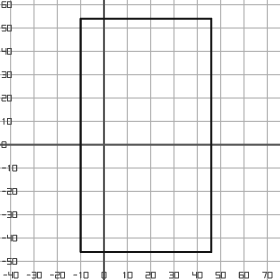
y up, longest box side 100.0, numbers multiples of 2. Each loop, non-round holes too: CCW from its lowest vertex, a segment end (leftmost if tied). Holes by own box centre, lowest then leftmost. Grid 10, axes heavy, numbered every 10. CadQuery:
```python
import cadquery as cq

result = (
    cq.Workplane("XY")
    .moveTo(-10.0, -46.0)
    .lineTo(46.0, -46.0)
    .lineTo(46.0, 54.0)
    .lineTo(-10.0, 54.0)
    .close()
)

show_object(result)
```